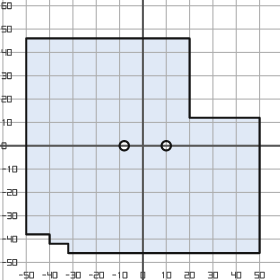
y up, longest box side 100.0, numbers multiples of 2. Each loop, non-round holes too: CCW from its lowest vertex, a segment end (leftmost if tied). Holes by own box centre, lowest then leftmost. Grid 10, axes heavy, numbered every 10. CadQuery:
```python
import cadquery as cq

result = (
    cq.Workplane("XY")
    .moveTo(-32.0, -46.0)
    .lineTo(50.0, -46.0)
    .lineTo(50.0, 12.0)
    .lineTo(20.0, 12.0)
    .lineTo(20.0, 46.0)
    .lineTo(-50.0, 46.0)
    .lineTo(-50.0, -38.0)
    .lineTo(-40.0, -38.0)
    .lineTo(-40.0, -42.0)
    .lineTo(-32.0, -42.0)
    .close()
    .moveTo(-8.0, 0.0)
    .circle(2.0)
    .moveTo(10.0, 0.0)
    .circle(2.0)
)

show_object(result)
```